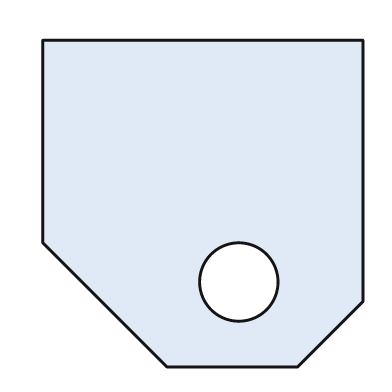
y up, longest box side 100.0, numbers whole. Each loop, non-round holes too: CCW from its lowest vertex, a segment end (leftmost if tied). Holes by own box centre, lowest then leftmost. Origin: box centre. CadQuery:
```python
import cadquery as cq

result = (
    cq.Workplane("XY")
    .moveTo(-11.0, -50.0)
    .lineTo(29.0, -50.0)
    .lineTo(49.0, -30.0)
    .lineTo(49.0, 50.0)
    .lineTo(-49.0, 50.0)
    .lineTo(-49.0, -12.0)
    .close()
    .moveTo(11.0, -24.0)
    .circle(12.0)
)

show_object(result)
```